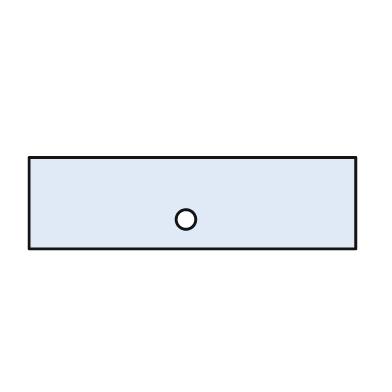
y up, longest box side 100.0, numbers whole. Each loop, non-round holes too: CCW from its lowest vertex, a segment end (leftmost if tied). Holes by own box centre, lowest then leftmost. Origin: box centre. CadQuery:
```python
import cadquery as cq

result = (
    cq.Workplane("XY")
    .moveTo(-50.0, -14.0)
    .lineTo(50.0, -14.0)
    .lineTo(50.0, 14.0)
    .lineTo(-50.0, 14.0)
    .close()
    .moveTo(-2.0, -5.0)
    .circle(3.0)
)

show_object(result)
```